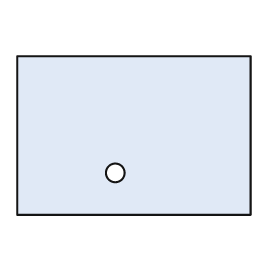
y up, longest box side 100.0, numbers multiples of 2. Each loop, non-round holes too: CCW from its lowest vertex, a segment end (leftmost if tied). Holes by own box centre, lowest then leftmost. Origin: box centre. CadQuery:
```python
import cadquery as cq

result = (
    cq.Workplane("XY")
    .moveTo(-50.0, -34.0)
    .lineTo(50.0, -34.0)
    .lineTo(50.0, 34.0)
    .lineTo(-50.0, 34.0)
    .close()
    .moveTo(-8.0, -16.0)
    .circle(4.0)
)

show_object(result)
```